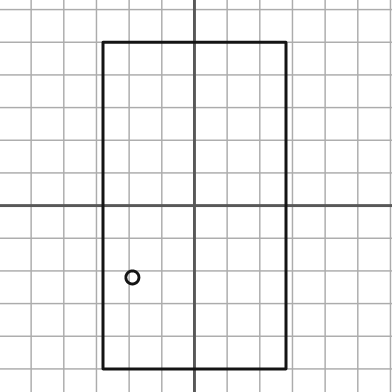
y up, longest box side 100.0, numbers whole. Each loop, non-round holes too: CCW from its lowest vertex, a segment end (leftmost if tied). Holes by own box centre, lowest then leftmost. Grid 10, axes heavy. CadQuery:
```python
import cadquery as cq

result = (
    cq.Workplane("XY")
    .moveTo(-28.0, -50.0)
    .lineTo(28.0, -50.0)
    .lineTo(28.0, 50.0)
    .lineTo(-28.0, 50.0)
    .close()
    .moveTo(-19.0, -22.0)
    .circle(2.0)
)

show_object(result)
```